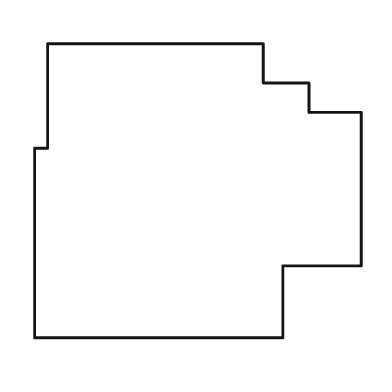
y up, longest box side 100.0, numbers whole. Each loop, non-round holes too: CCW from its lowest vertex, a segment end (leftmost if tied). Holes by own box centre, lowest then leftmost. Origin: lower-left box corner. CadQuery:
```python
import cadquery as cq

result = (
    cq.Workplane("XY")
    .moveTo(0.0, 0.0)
    .lineTo(76.0, 0.0)
    .lineTo(76.0, 22.0)
    .lineTo(100.0, 22.0)
    .lineTo(100.0, 69.0)
    .lineTo(84.0, 69.0)
    .lineTo(84.0, 78.0)
    .lineTo(70.0, 78.0)
    .lineTo(70.0, 90.0)
    .lineTo(4.0, 90.0)
    .lineTo(4.0, 58.0)
    .lineTo(0.0, 58.0)
    .close()
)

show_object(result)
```